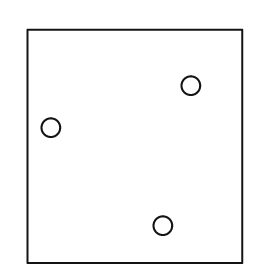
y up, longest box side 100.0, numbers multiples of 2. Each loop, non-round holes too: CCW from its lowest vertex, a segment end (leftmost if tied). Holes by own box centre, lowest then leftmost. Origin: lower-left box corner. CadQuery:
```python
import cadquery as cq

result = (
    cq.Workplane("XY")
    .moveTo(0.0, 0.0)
    .lineTo(92.0, 0.0)
    .lineTo(92.0, 100.0)
    .lineTo(0.0, 100.0)
    .close()
    .moveTo(58.0, 16.0)
    .circle(4.0)
    .moveTo(10.0, 58.0)
    .circle(4.0)
    .moveTo(70.0, 76.0)
    .circle(4.0)
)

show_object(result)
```